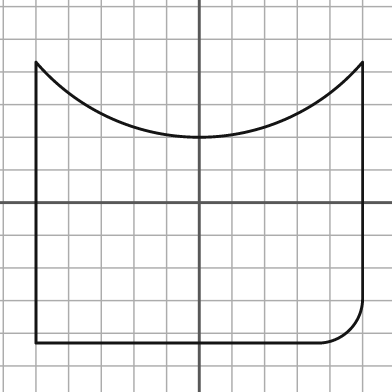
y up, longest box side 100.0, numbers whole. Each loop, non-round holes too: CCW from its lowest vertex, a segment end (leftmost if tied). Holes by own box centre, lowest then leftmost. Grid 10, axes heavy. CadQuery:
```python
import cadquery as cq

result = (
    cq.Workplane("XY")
    .moveTo(-50.0, -43.0)
    .lineTo(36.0, -43.0)
    .threePointArc((46.0, -39.0), (50.0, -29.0))
    .lineTo(50.0, 43.0)
    .threePointArc((0.0, 20.0), (-50.0, 43.0))
    .close()
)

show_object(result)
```